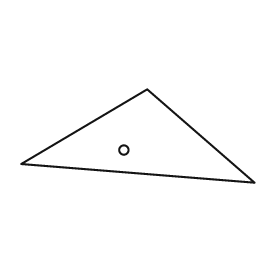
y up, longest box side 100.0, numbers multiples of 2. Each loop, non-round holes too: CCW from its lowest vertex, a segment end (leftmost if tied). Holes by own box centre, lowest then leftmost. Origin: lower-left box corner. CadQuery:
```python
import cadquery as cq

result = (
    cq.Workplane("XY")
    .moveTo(100.0, 0.0)
    .lineTo(54.0, 40.0)
    .lineTo(0.0, 8.0)
    .close()
    .moveTo(44.0, 14.0)
    .circle(2.0)
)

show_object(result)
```